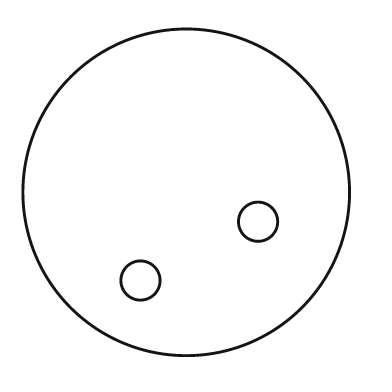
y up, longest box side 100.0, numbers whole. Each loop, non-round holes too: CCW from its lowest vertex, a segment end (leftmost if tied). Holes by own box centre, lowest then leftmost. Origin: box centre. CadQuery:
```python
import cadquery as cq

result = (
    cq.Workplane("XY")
    .moveTo(0.0, 0.0)
    .circle(50.0)
    .moveTo(-14.0, -27.0)
    .circle(6.0)
    .moveTo(22.0, -9.0)
    .circle(6.0)
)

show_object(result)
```